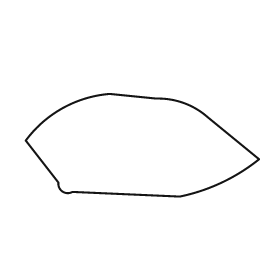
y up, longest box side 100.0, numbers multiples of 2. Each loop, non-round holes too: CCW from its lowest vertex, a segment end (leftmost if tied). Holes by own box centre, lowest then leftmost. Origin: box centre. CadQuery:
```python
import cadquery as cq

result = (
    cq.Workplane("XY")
    .moveTo(16.0, -22.0)
    .threePointArc((34.0, -16.0), (50.0, -6.0))
    .lineTo(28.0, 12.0)
    .threePointArc((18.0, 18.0), (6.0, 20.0))
    .lineTo(-14.0, 22.0)
    .threePointArc((-34.0, 16.0), (-50.0, 2.0))
    .lineTo(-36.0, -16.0)
    .threePointArc((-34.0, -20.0), (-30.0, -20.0))
    .close()
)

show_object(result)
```